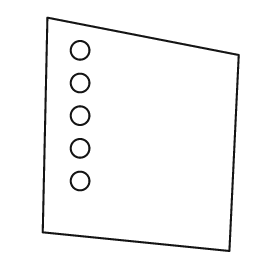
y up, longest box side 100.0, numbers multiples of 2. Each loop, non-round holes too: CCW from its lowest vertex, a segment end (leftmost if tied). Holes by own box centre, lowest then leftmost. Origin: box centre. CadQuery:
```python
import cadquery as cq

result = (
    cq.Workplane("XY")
    .moveTo(38.0, -50.0)
    .lineTo(42.0, 34.0)
    .lineTo(-40.0, 50.0)
    .lineTo(-42.0, -42.0)
    .close()
    .moveTo(-26.0, -20.0)
    .circle(4.0)
    .moveTo(-26.0, -6.0)
    .circle(4.0)
    .moveTo(-26.0, 8.0)
    .circle(4.0)
    .moveTo(-26.0, 22.0)
    .circle(4.0)
    .moveTo(-26.0, 36.0)
    .circle(4.0)
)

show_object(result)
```